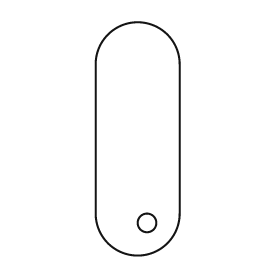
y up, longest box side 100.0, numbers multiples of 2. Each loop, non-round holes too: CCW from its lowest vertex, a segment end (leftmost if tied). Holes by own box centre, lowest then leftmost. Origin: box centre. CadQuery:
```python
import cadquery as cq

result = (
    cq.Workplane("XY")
    .moveTo(-18.0, -32.0)
    .threePointArc((0.0, -50.0), (18.0, -32.0))
    .lineTo(18.0, 32.0)
    .threePointArc((0.0, 50.0), (-18.0, 32.0))
    .close()
    .moveTo(4.0, -36.0)
    .circle(4.0)
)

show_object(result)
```